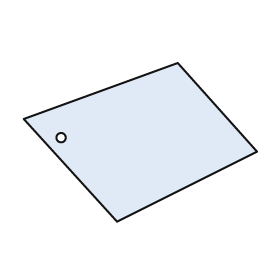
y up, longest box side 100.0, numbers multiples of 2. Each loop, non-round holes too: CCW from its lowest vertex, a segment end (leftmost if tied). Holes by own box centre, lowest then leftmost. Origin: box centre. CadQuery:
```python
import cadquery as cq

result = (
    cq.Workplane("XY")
    .moveTo(-10.0, -34.0)
    .lineTo(50.0, -4.0)
    .lineTo(16.0, 34.0)
    .lineTo(-50.0, 10.0)
    .close()
    .moveTo(-34.0, 2.0)
    .circle(2.0)
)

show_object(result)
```